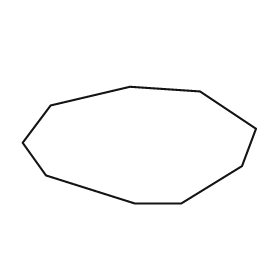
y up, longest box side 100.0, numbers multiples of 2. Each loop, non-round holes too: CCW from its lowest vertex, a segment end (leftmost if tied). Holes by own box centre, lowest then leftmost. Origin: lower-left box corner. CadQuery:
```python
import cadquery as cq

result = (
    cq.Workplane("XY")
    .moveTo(48.0, 0.0)
    .lineTo(68.0, 0.0)
    .lineTo(94.0, 16.0)
    .lineTo(100.0, 32.0)
    .lineTo(76.0, 48.0)
    .lineTo(46.0, 50.0)
    .lineTo(12.0, 42.0)
    .lineTo(0.0, 26.0)
    .lineTo(10.0, 12.0)
    .close()
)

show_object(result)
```